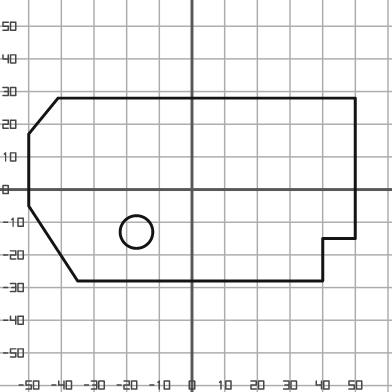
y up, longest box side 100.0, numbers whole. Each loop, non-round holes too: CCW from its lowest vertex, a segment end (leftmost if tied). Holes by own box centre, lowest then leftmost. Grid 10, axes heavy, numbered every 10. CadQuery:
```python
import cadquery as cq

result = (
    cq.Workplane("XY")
    .moveTo(-35.0, -28.0)
    .lineTo(40.0, -28.0)
    .lineTo(40.0, -15.0)
    .lineTo(50.0, -15.0)
    .lineTo(50.0, 28.0)
    .lineTo(-41.0, 28.0)
    .lineTo(-50.0, 17.0)
    .lineTo(-50.0, -5.0)
    .close()
    .moveTo(-17.0, -13.0)
    .circle(5.0)
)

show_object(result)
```